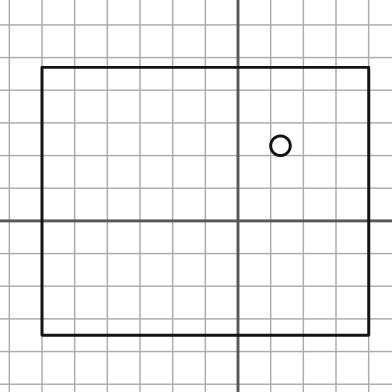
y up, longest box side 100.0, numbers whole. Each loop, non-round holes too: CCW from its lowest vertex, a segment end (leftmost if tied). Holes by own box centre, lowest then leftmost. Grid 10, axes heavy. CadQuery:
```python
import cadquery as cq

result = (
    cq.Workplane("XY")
    .moveTo(-60.0, -35.0)
    .lineTo(40.0, -35.0)
    .lineTo(40.0, 47.0)
    .lineTo(-60.0, 47.0)
    .close()
    .moveTo(13.0, 23.0)
    .circle(3.0)
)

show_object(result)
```